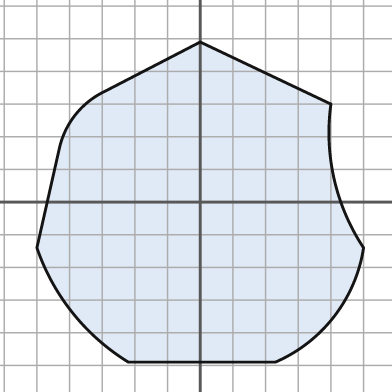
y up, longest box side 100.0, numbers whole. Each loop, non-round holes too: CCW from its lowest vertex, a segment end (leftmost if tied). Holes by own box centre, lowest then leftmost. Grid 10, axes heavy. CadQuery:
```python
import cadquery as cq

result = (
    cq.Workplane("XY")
    .moveTo(-22.0, -49.0)
    .lineTo(23.0, -49.0)
    .threePointArc((41.0, -35.0), (50.0, -14.0))
    .threePointArc((41.0, 7.0), (40.0, 30.0))
    .lineTo(0.0, 49.0)
    .lineTo(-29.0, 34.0)
    .threePointArc((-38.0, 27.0), (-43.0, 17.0))
    .lineTo(-50.0, -14.0)
    .threePointArc((-39.0, -34.0), (-22.0, -49.0))
    .close()
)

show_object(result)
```